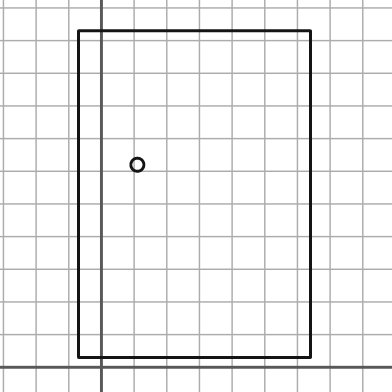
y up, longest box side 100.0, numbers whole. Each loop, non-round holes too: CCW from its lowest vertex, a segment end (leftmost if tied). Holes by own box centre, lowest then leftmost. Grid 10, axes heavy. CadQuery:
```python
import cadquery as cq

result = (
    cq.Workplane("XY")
    .moveTo(-7.0, 3.0)
    .lineTo(64.0, 3.0)
    .lineTo(64.0, 103.0)
    .lineTo(-7.0, 103.0)
    .close()
    .moveTo(11.0, 62.0)
    .circle(2.0)
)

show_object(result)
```